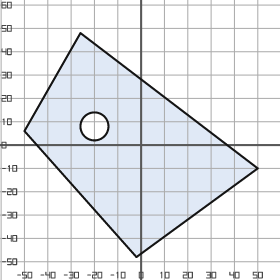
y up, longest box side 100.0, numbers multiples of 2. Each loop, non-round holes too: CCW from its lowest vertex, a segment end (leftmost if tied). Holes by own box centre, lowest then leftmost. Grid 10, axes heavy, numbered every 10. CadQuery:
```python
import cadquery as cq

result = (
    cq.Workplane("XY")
    .moveTo(-2.0, -48.0)
    .lineTo(50.0, -10.0)
    .lineTo(-26.0, 48.0)
    .lineTo(-50.0, 6.0)
    .close()
    .moveTo(-20.0, 8.0)
    .circle(6.0)
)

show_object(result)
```